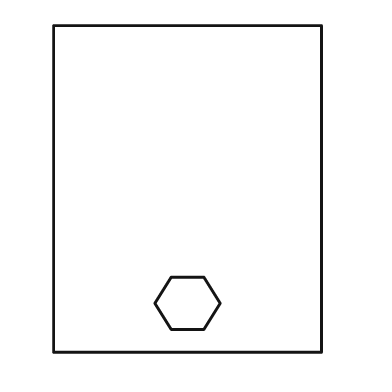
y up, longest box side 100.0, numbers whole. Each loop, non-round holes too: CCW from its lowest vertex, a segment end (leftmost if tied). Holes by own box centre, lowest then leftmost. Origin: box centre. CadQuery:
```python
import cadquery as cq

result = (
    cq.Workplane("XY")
    .moveTo(-41.0, -50.0)
    .lineTo(41.0, -50.0)
    .lineTo(41.0, 50.0)
    .lineTo(-41.0, 50.0)
    .close()
    .moveTo(-5.0, -43.0)
    .lineTo(5.0, -43.0)
    .lineTo(10.0, -35.0)
    .lineTo(5.0, -27.0)
    .lineTo(-5.0, -27.0)
    .lineTo(-10.0, -35.0)
    .close()
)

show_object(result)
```